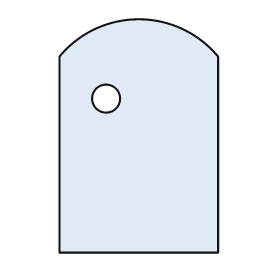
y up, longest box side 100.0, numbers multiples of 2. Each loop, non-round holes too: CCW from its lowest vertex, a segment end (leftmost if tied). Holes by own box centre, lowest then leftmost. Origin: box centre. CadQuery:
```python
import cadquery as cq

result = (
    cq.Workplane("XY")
    .moveTo(-34.0, -50.0)
    .lineTo(34.0, -50.0)
    .lineTo(34.0, 34.0)
    .threePointArc((0.0, 50.0), (-34.0, 34.0))
    .close()
    .moveTo(-14.0, 16.0)
    .circle(6.0)
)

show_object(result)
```